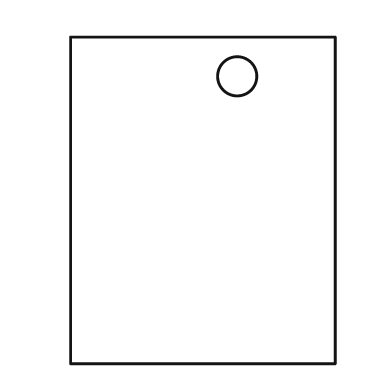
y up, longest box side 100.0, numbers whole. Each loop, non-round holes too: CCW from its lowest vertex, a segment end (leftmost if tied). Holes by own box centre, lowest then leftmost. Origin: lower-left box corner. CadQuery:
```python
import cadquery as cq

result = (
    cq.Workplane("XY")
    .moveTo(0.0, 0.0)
    .lineTo(81.0, 0.0)
    .lineTo(81.0, 100.0)
    .lineTo(0.0, 100.0)
    .close()
    .moveTo(51.0, 88.0)
    .circle(6.0)
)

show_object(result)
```